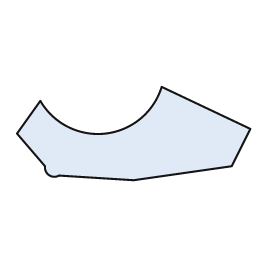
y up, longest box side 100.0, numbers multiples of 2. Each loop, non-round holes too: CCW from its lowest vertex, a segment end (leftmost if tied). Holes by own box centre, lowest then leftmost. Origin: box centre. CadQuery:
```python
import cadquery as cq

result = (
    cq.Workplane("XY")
    .moveTo(0.0, -20.0)
    .lineTo(42.0, -14.0)
    .lineTo(50.0, 2.0)
    .lineTo(12.0, 20.0)
    .threePointArc((-12.0, 0.0), (-40.0, 14.0))
    .lineTo(-50.0, 0.0)
    .lineTo(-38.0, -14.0)
    .threePointArc((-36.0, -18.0), (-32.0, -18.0))
    .close()
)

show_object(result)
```